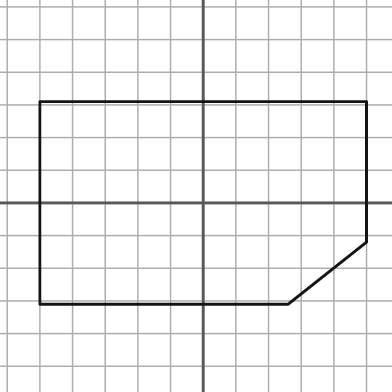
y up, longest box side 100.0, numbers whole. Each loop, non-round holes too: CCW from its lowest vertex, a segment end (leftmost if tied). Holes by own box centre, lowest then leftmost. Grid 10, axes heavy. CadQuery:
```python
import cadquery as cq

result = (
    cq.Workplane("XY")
    .moveTo(-50.0, -31.0)
    .lineTo(26.0, -31.0)
    .lineTo(50.0, -12.0)
    .lineTo(50.0, 31.0)
    .lineTo(-50.0, 31.0)
    .close()
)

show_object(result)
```